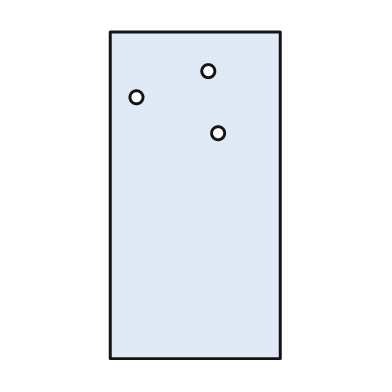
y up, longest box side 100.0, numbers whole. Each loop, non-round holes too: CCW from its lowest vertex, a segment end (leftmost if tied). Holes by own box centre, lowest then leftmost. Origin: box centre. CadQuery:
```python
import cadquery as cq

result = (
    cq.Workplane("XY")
    .moveTo(-26.0, -50.0)
    .lineTo(26.0, -50.0)
    .lineTo(26.0, 50.0)
    .lineTo(-26.0, 50.0)
    .close()
    .moveTo(7.0, 19.0)
    .circle(2.0)
    .moveTo(-18.0, 30.0)
    .circle(2.0)
    .moveTo(4.0, 38.0)
    .circle(2.0)
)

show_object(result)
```